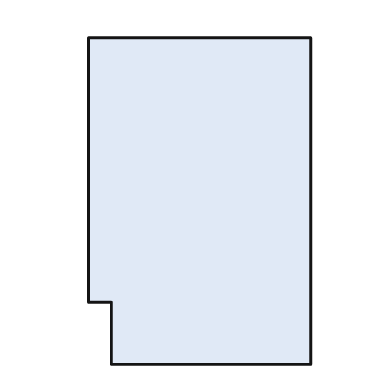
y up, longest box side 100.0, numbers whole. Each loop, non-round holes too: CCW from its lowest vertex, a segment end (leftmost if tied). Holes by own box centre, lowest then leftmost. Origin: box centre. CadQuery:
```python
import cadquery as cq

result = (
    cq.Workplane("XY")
    .moveTo(-27.0, -50.0)
    .lineTo(34.0, -50.0)
    .lineTo(34.0, 50.0)
    .lineTo(-34.0, 50.0)
    .lineTo(-34.0, -31.0)
    .lineTo(-27.0, -31.0)
    .close()
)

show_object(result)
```